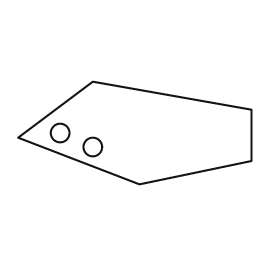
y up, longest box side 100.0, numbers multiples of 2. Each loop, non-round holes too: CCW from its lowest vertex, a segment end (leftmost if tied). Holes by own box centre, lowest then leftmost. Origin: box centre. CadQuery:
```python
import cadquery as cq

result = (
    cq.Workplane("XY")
    .moveTo(2.0, -22.0)
    .lineTo(50.0, -12.0)
    .lineTo(50.0, 10.0)
    .lineTo(-18.0, 22.0)
    .lineTo(-50.0, -2.0)
    .close()
    .moveTo(-18.0, -6.0)
    .circle(4.0)
    .moveTo(-32.0, 0.0)
    .circle(4.0)
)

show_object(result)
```